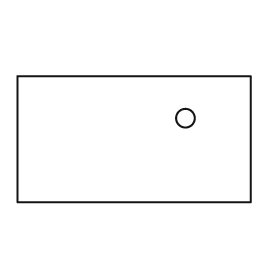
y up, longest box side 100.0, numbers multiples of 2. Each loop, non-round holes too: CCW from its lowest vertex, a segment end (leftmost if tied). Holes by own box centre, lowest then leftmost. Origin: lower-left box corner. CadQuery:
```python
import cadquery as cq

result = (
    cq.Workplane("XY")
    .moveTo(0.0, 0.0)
    .lineTo(100.0, 0.0)
    .lineTo(100.0, 54.0)
    .lineTo(0.0, 54.0)
    .close()
    .moveTo(72.0, 36.0)
    .circle(4.0)
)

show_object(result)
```